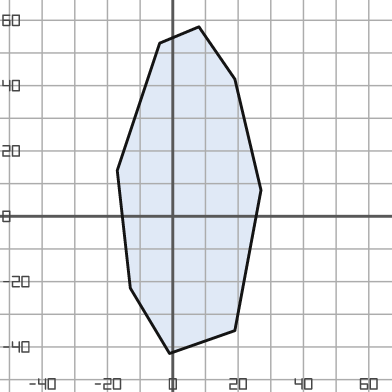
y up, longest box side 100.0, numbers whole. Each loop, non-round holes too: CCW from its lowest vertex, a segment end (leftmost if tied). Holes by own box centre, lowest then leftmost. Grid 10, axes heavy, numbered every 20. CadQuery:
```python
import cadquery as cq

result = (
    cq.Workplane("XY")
    .moveTo(-1.0, -42.0)
    .lineTo(19.0, -35.0)
    .lineTo(27.0, 8.0)
    .lineTo(19.0, 42.0)
    .lineTo(8.0, 58.0)
    .lineTo(-4.0, 53.0)
    .lineTo(-17.0, 14.0)
    .lineTo(-13.0, -22.0)
    .close()
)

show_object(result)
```